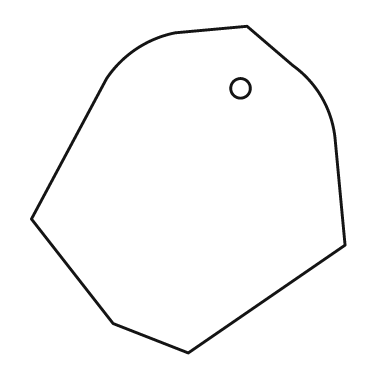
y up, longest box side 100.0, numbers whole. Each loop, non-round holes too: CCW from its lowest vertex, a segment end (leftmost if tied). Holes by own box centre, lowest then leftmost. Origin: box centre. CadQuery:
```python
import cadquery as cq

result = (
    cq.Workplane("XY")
    .moveTo(0.0, -50.0)
    .lineTo(48.0, -17.0)
    .lineTo(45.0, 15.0)
    .threePointArc((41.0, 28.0), (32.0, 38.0))
    .lineTo(18.0, 50.0)
    .lineTo(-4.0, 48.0)
    .threePointArc((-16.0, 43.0), (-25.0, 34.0))
    .lineTo(-48.0, -9.0)
    .lineTo(-23.0, -41.0)
    .close()
    .moveTo(16.0, 31.0)
    .circle(3.0)
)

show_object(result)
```